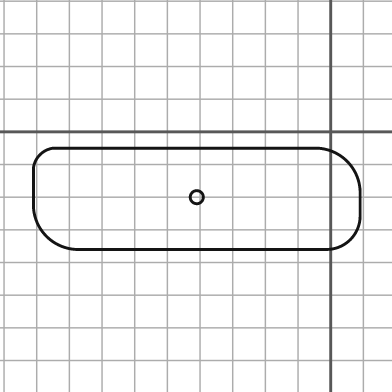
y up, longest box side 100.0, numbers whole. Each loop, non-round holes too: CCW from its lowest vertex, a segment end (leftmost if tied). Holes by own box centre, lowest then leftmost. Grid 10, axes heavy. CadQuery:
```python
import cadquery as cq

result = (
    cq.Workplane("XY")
    .moveTo(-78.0, -36.0)
    .lineTo(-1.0, -36.0)
    .threePointArc((6.0, -33.0), (9.0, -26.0))
    .lineTo(9.0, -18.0)
    .threePointArc((5.0, -9.0), (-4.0, -5.0))
    .lineTo(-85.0, -5.0)
    .threePointArc((-89.0, -7.0), (-91.0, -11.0))
    .lineTo(-91.0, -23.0)
    .threePointArc((-87.0, -32.0), (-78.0, -36.0))
    .close()
    .moveTo(-41.0, -20.0)
    .circle(2.0)
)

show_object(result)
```